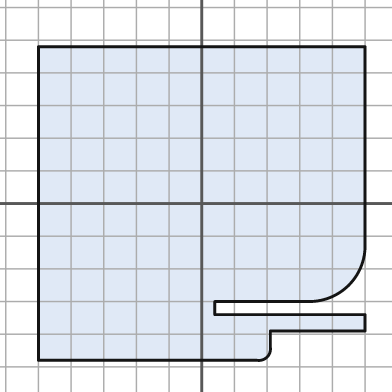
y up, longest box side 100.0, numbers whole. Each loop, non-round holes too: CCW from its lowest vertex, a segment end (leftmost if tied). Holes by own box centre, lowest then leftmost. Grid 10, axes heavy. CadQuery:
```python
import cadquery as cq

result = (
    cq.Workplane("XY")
    .moveTo(-50.0, -48.0)
    .lineTo(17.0, -48.0)
    .threePointArc((20.0, -47.0), (21.0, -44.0))
    .lineTo(21.0, -39.0)
    .lineTo(50.0, -39.0)
    .lineTo(50.0, -34.0)
    .lineTo(4.0, -34.0)
    .lineTo(4.0, -30.0)
    .lineTo(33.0, -30.0)
    .threePointArc((45.0, -25.0), (50.0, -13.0))
    .lineTo(50.0, 48.0)
    .lineTo(-50.0, 48.0)
    .close()
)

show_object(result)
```